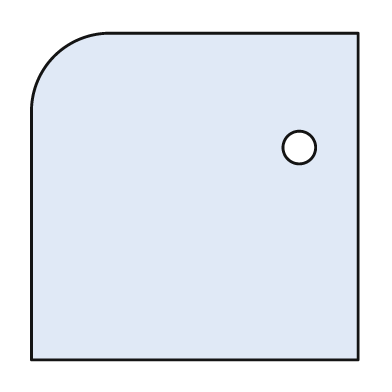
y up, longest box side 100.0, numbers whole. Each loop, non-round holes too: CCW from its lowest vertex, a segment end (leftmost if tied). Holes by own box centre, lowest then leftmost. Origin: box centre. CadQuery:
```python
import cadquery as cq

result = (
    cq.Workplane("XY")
    .moveTo(-50.0, -50.0)
    .lineTo(50.0, -50.0)
    .lineTo(50.0, 50.0)
    .lineTo(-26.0, 50.0)
    .threePointArc((-43.0, 43.0), (-50.0, 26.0))
    .close()
    .moveTo(32.0, 15.0)
    .circle(5.0)
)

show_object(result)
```